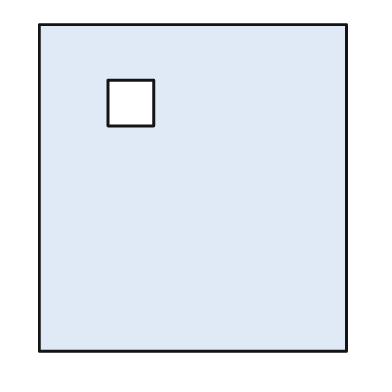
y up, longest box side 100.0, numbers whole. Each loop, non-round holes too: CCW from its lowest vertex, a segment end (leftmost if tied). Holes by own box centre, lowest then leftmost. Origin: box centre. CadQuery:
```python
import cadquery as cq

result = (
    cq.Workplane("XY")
    .moveTo(-47.0, -50.0)
    .lineTo(47.0, -50.0)
    .lineTo(47.0, 50.0)
    .lineTo(-47.0, 50.0)
    .close()
    .moveTo(-26.0, 19.0)
    .lineTo(-12.0, 19.0)
    .lineTo(-12.0, 33.0)
    .lineTo(-26.0, 33.0)
    .close()
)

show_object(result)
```